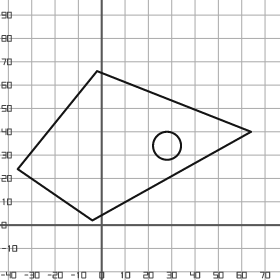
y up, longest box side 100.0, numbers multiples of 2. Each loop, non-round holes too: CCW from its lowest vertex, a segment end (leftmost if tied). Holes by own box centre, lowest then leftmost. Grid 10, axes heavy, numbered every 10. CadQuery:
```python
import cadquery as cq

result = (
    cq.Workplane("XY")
    .moveTo(-4.0, 2.0)
    .lineTo(64.0, 40.0)
    .lineTo(-2.0, 66.0)
    .lineTo(-36.0, 24.0)
    .close()
    .moveTo(28.0, 34.0)
    .circle(6.0)
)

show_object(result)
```